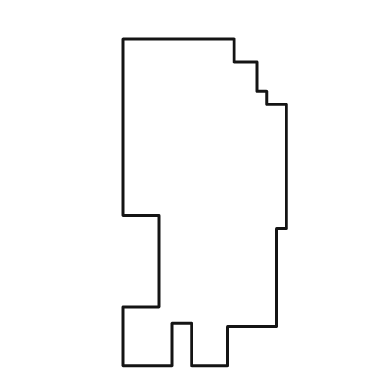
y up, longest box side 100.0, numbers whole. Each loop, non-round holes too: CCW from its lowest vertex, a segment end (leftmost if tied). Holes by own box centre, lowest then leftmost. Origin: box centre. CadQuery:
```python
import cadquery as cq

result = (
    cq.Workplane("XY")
    .moveTo(-25.0, -50.0)
    .lineTo(-10.0, -50.0)
    .lineTo(-10.0, -37.0)
    .lineTo(-4.0, -37.0)
    .lineTo(-4.0, -50.0)
    .lineTo(7.0, -50.0)
    .lineTo(7.0, -38.0)
    .lineTo(22.0, -38.0)
    .lineTo(22.0, -8.0)
    .lineTo(25.0, -8.0)
    .lineTo(25.0, 30.0)
    .lineTo(19.0, 30.0)
    .lineTo(19.0, 34.0)
    .lineTo(16.0, 34.0)
    .lineTo(16.0, 43.0)
    .lineTo(9.0, 43.0)
    .lineTo(9.0, 50.0)
    .lineTo(-25.0, 50.0)
    .lineTo(-25.0, -4.0)
    .lineTo(-14.0, -4.0)
    .lineTo(-14.0, -32.0)
    .lineTo(-25.0, -32.0)
    .close()
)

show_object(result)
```